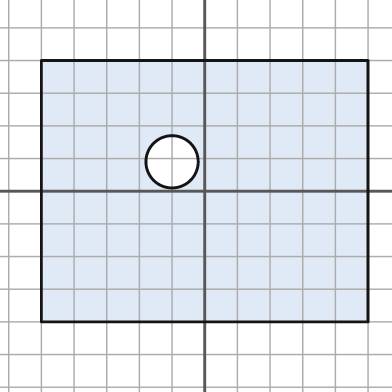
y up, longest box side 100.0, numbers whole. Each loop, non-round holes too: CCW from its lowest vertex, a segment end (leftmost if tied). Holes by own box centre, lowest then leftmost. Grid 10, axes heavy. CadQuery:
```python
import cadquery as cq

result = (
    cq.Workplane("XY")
    .moveTo(-50.0, -40.0)
    .lineTo(50.0, -40.0)
    .lineTo(50.0, 40.0)
    .lineTo(-50.0, 40.0)
    .close()
    .moveTo(-10.0, 9.0)
    .circle(8.0)
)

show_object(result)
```